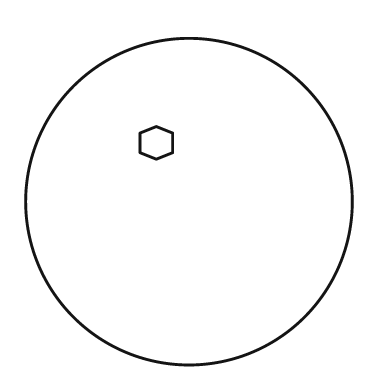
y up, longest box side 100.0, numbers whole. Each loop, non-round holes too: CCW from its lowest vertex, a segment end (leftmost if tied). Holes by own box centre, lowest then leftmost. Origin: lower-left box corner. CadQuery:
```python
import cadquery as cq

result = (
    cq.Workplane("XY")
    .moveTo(50.0, 50.0)
    .circle(50.0)
    .moveTo(40.0, 63.0)
    .lineTo(45.0, 65.0)
    .lineTo(45.0, 71.0)
    .lineTo(40.0, 73.0)
    .lineTo(35.0, 71.0)
    .lineTo(35.0, 65.0)
    .close()
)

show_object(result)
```